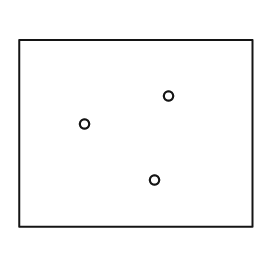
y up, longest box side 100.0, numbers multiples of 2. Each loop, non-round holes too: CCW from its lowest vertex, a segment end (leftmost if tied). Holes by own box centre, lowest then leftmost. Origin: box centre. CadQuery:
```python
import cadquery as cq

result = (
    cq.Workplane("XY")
    .moveTo(-50.0, -40.0)
    .lineTo(50.0, -40.0)
    .lineTo(50.0, 40.0)
    .lineTo(-50.0, 40.0)
    .close()
    .moveTo(8.0, -20.0)
    .circle(2.0)
    .moveTo(-22.0, 4.0)
    .circle(2.0)
    .moveTo(14.0, 16.0)
    .circle(2.0)
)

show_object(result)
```